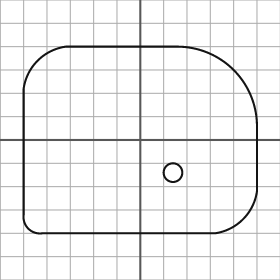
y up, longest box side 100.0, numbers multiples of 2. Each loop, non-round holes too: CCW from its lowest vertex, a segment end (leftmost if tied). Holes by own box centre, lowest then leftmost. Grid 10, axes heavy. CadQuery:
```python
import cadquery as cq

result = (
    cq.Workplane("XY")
    .moveTo(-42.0, -40.0)
    .lineTo(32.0, -40.0)
    .threePointArc((44.0, -34.0), (50.0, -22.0))
    .lineTo(50.0, 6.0)
    .threePointArc((40.0, 30.0), (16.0, 40.0))
    .lineTo(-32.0, 40.0)
    .threePointArc((-44.0, 34.0), (-50.0, 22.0))
    .lineTo(-50.0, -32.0)
    .threePointArc((-48.0, -38.0), (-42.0, -40.0))
    .close()
    .moveTo(14.0, -14.0)
    .circle(4.0)
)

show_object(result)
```